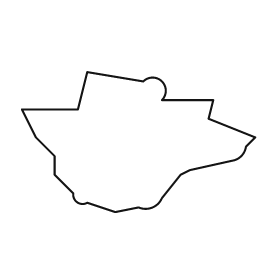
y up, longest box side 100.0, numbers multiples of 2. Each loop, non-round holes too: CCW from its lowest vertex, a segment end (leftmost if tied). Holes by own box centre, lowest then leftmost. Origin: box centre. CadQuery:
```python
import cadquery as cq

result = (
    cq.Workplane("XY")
    .moveTo(-10.0, -30.0)
    .lineTo(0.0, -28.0)
    .threePointArc((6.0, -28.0), (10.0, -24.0))
    .lineTo(18.0, -14.0)
    .lineTo(22.0, -12.0)
    .lineTo(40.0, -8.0)
    .threePointArc((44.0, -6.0), (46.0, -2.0))
    .lineTo(50.0, 2.0)
    .lineTo(30.0, 10.0)
    .lineTo(32.0, 18.0)
    .lineTo(10.0, 18.0)
    .threePointArc((10.0, 26.0), (2.0, 26.0))
    .lineTo(-22.0, 30.0)
    .lineTo(-26.0, 14.0)
    .lineTo(-50.0, 14.0)
    .lineTo(-44.0, 2.0)
    .lineTo(-36.0, -6.0)
    .lineTo(-36.0, -14.0)
    .lineTo(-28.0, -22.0)
    .threePointArc((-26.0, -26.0), (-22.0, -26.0))
    .close()
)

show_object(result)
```